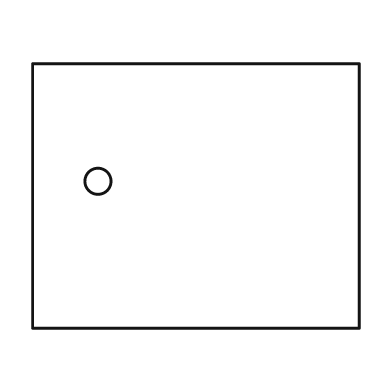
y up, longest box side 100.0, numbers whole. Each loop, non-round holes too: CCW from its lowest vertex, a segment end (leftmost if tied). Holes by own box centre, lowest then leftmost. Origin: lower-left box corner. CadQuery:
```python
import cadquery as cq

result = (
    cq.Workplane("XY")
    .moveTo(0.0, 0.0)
    .lineTo(100.0, 0.0)
    .lineTo(100.0, 81.0)
    .lineTo(0.0, 81.0)
    .close()
    .moveTo(20.0, 45.0)
    .circle(4.0)
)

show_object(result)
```